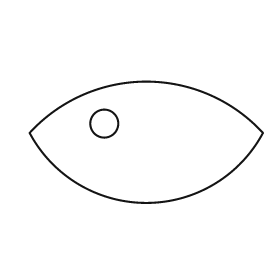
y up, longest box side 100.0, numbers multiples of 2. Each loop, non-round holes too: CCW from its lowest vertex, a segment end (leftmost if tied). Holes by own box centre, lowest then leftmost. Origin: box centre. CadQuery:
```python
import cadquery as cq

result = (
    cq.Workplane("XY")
    .moveTo(-50.0, 4.0)
    .threePointArc((0.0, -26.0), (50.0, 4.0))
    .threePointArc((0.0, 26.0), (-50.0, 4.0))
    .close()
    .moveTo(-18.0, 8.0)
    .circle(6.0)
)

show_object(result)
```